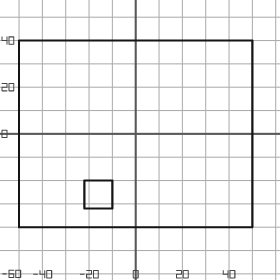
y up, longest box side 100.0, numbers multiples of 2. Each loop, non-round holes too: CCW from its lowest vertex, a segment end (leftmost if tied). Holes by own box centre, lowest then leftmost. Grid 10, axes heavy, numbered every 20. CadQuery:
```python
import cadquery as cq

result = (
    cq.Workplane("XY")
    .moveTo(-50.0, -40.0)
    .lineTo(50.0, -40.0)
    .lineTo(50.0, 40.0)
    .lineTo(-50.0, 40.0)
    .close()
    .moveTo(-22.0, -32.0)
    .lineTo(-10.0, -32.0)
    .lineTo(-10.0, -20.0)
    .lineTo(-22.0, -20.0)
    .close()
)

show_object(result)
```